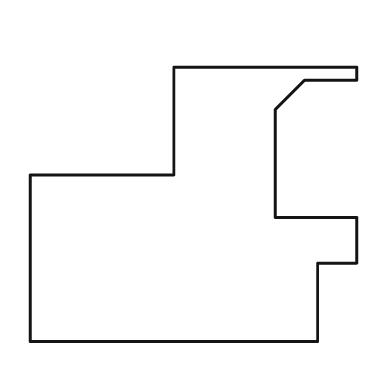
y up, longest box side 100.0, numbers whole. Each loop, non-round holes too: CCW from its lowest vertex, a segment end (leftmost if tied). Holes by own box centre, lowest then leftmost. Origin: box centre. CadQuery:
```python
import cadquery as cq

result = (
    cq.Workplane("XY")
    .moveTo(-50.0, -42.0)
    .lineTo(38.0, -42.0)
    .lineTo(38.0, -18.0)
    .lineTo(50.0, -18.0)
    .lineTo(50.0, -4.0)
    .lineTo(25.0, -4.0)
    .lineTo(25.0, 29.0)
    .lineTo(34.0, 38.0)
    .lineTo(50.0, 38.0)
    .lineTo(50.0, 42.0)
    .lineTo(-6.0, 42.0)
    .lineTo(-6.0, 9.0)
    .lineTo(-50.0, 9.0)
    .close()
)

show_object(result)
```